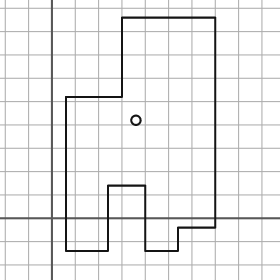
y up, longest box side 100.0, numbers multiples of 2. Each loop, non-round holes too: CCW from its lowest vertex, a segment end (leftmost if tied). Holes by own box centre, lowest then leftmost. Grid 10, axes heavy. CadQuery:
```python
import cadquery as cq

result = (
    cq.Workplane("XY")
    .moveTo(6.0, -14.0)
    .lineTo(24.0, -14.0)
    .lineTo(24.0, 14.0)
    .lineTo(40.0, 14.0)
    .lineTo(40.0, -14.0)
    .lineTo(54.0, -14.0)
    .lineTo(54.0, -4.0)
    .lineTo(70.0, -4.0)
    .lineTo(70.0, 86.0)
    .lineTo(30.0, 86.0)
    .lineTo(30.0, 52.0)
    .lineTo(6.0, 52.0)
    .close()
    .moveTo(36.0, 42.0)
    .circle(2.0)
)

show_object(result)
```